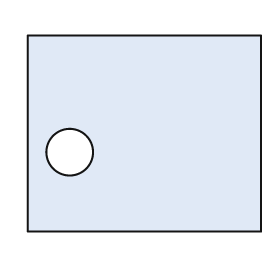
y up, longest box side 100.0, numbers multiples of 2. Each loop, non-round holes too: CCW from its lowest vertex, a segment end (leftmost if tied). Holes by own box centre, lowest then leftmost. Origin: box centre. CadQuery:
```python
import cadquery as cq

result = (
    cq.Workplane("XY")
    .moveTo(-50.0, -42.0)
    .lineTo(50.0, -42.0)
    .lineTo(50.0, 42.0)
    .lineTo(-50.0, 42.0)
    .close()
    .moveTo(-32.0, -8.0)
    .circle(10.0)
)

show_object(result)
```